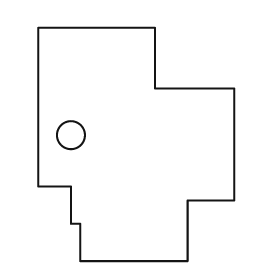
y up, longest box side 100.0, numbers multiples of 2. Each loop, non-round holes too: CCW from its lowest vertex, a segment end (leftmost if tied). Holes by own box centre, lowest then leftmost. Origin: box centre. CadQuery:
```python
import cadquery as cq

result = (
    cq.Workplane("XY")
    .moveTo(-24.0, -50.0)
    .lineTo(22.0, -50.0)
    .lineTo(22.0, -24.0)
    .lineTo(42.0, -24.0)
    .lineTo(42.0, 24.0)
    .lineTo(8.0, 24.0)
    .lineTo(8.0, 50.0)
    .lineTo(-42.0, 50.0)
    .lineTo(-42.0, -18.0)
    .lineTo(-28.0, -18.0)
    .lineTo(-28.0, -34.0)
    .lineTo(-24.0, -34.0)
    .close()
    .moveTo(-28.0, 4.0)
    .circle(6.0)
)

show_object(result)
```